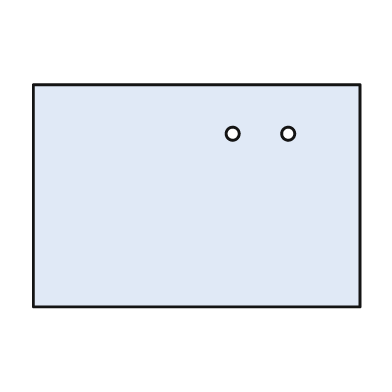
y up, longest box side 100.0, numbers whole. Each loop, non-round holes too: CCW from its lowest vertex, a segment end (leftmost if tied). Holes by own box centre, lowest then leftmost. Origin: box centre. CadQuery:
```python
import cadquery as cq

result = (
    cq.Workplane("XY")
    .moveTo(-50.0, -34.0)
    .lineTo(50.0, -34.0)
    .lineTo(50.0, 34.0)
    .lineTo(-50.0, 34.0)
    .close()
    .moveTo(11.0, 19.0)
    .circle(2.0)
    .moveTo(28.0, 19.0)
    .circle(2.0)
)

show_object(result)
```